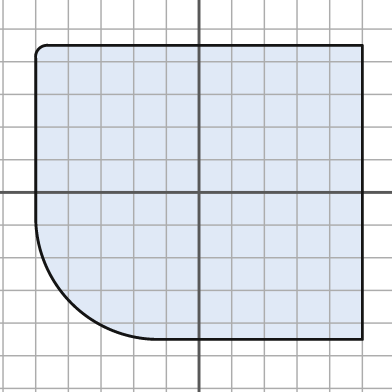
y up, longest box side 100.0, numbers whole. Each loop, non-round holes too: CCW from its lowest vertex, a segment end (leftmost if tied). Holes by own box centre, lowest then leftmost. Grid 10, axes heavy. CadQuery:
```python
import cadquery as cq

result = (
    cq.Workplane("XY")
    .moveTo(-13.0, -45.0)
    .lineTo(50.0, -45.0)
    .lineTo(50.0, 45.0)
    .lineTo(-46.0, 45.0)
    .threePointArc((-49.0, 44.0), (-50.0, 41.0))
    .lineTo(-50.0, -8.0)
    .threePointArc((-39.0, -34.0), (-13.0, -45.0))
    .close()
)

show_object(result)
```